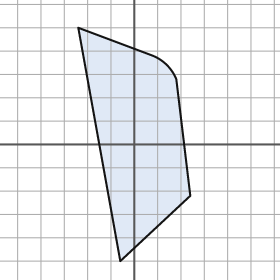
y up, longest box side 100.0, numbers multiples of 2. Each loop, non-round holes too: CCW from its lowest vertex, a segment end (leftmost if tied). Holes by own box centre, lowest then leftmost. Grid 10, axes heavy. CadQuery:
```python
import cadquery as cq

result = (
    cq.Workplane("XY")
    .moveTo(-6.0, -50.0)
    .lineTo(24.0, -22.0)
    .lineTo(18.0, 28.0)
    .threePointArc((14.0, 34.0), (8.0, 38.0))
    .lineTo(-24.0, 50.0)
    .close()
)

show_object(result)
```